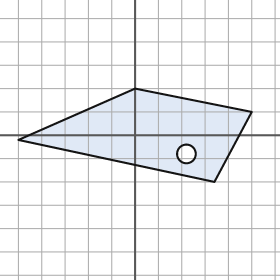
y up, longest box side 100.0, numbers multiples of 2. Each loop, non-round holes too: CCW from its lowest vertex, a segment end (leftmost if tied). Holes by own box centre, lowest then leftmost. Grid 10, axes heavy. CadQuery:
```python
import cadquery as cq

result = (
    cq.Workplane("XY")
    .moveTo(34.0, -20.0)
    .lineTo(50.0, 10.0)
    .lineTo(0.0, 20.0)
    .lineTo(-50.0, -2.0)
    .close()
    .moveTo(22.0, -8.0)
    .circle(4.0)
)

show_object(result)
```